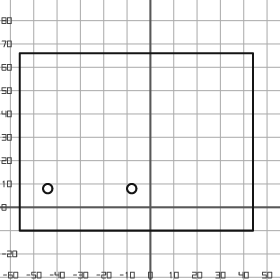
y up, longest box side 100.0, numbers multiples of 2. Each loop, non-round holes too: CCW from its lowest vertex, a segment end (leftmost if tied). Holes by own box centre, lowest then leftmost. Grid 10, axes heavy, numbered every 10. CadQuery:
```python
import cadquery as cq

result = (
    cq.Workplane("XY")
    .moveTo(-56.0, -10.0)
    .lineTo(44.0, -10.0)
    .lineTo(44.0, 66.0)
    .lineTo(-56.0, 66.0)
    .close()
    .moveTo(-44.0, 8.0)
    .circle(2.0)
    .moveTo(-8.0, 8.0)
    .circle(2.0)
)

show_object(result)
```